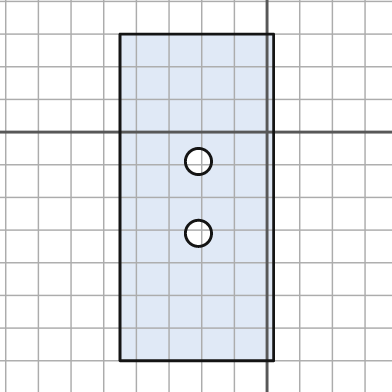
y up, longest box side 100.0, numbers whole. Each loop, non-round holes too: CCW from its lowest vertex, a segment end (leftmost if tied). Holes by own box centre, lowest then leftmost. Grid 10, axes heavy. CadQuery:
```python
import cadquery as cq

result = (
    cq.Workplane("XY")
    .moveTo(-45.0, -70.0)
    .lineTo(2.0, -70.0)
    .lineTo(2.0, 30.0)
    .lineTo(-45.0, 30.0)
    .close()
    .moveTo(-21.0, -31.0)
    .circle(4.0)
    .moveTo(-21.0, -9.0)
    .circle(4.0)
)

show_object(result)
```